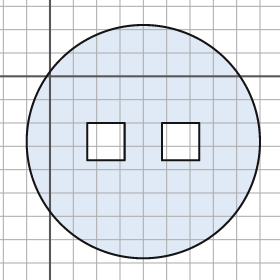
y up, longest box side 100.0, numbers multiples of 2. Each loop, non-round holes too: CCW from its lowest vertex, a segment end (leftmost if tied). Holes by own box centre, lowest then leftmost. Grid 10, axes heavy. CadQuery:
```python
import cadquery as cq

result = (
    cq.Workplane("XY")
    .moveTo(40.0, -28.0)
    .circle(50.0)
    .moveTo(16.0, -36.0)
    .lineTo(32.0, -36.0)
    .lineTo(32.0, -20.0)
    .lineTo(16.0, -20.0)
    .close()
    .moveTo(48.0, -36.0)
    .lineTo(64.0, -36.0)
    .lineTo(64.0, -20.0)
    .lineTo(48.0, -20.0)
    .close()
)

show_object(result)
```